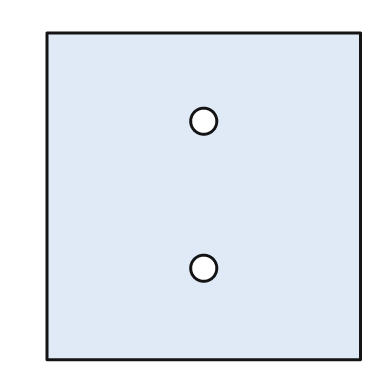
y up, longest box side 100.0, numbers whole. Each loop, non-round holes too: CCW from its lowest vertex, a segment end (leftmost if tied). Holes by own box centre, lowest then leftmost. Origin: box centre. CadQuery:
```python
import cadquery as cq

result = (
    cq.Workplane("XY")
    .moveTo(-48.0, -50.0)
    .lineTo(48.0, -50.0)
    .lineTo(48.0, 50.0)
    .lineTo(-48.0, 50.0)
    .close()
    .moveTo(0.0, -22.0)
    .circle(4.0)
    .moveTo(0.0, 23.0)
    .circle(4.0)
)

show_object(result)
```